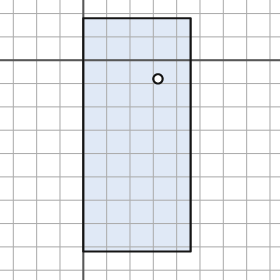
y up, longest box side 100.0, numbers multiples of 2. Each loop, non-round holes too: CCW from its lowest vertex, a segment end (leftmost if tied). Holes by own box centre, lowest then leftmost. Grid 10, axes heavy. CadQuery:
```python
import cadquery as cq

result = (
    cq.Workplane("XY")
    .moveTo(0.0, -82.0)
    .lineTo(46.0, -82.0)
    .lineTo(46.0, 18.0)
    .lineTo(0.0, 18.0)
    .close()
    .moveTo(32.0, -8.0)
    .circle(2.0)
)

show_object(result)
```